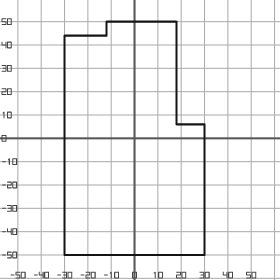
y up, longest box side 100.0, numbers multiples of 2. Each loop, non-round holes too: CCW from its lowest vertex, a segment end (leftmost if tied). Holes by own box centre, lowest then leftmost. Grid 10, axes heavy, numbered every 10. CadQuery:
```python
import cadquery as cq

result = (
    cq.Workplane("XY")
    .moveTo(-30.0, -50.0)
    .lineTo(30.0, -50.0)
    .lineTo(30.0, 6.0)
    .lineTo(18.0, 6.0)
    .lineTo(18.0, 50.0)
    .lineTo(-12.0, 50.0)
    .lineTo(-12.0, 44.0)
    .lineTo(-30.0, 44.0)
    .close()
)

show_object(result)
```